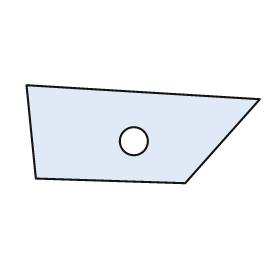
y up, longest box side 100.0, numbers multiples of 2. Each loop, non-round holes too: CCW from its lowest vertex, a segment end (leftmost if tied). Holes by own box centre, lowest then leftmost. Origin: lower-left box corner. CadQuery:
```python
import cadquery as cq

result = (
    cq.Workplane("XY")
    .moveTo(68.0, 0.0)
    .lineTo(100.0, 36.0)
    .lineTo(0.0, 42.0)
    .lineTo(4.0, 2.0)
    .close()
    .moveTo(46.0, 18.0)
    .circle(6.0)
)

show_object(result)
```